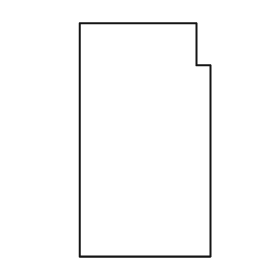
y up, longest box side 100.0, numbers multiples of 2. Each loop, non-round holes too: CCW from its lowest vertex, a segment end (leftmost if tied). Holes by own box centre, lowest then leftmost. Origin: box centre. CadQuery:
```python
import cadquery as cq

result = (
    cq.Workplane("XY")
    .moveTo(-28.0, -50.0)
    .lineTo(28.0, -50.0)
    .lineTo(28.0, 32.0)
    .lineTo(22.0, 32.0)
    .lineTo(22.0, 50.0)
    .lineTo(-28.0, 50.0)
    .close()
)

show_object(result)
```